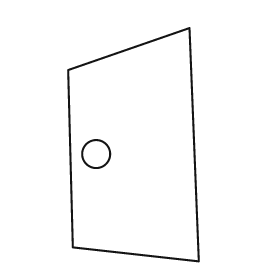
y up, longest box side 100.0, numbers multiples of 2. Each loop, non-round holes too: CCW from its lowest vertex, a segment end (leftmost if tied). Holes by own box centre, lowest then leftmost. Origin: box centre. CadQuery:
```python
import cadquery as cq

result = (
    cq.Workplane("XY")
    .moveTo(28.0, -50.0)
    .lineTo(24.0, 50.0)
    .lineTo(-28.0, 32.0)
    .lineTo(-26.0, -44.0)
    .close()
    .moveTo(-16.0, -4.0)
    .circle(6.0)
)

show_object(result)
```